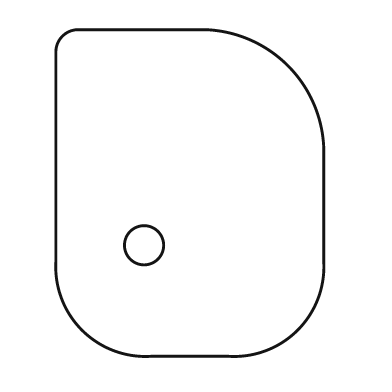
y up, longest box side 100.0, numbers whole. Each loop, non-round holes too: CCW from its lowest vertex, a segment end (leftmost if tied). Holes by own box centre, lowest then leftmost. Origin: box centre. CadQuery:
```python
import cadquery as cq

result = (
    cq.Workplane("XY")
    .moveTo(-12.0, -50.0)
    .lineTo(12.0, -50.0)
    .threePointArc((33.0, -42.0), (41.0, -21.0))
    .lineTo(41.0, 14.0)
    .threePointArc((30.0, 39.0), (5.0, 50.0))
    .lineTo(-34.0, 50.0)
    .threePointArc((-39.0, 48.0), (-41.0, 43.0))
    .lineTo(-41.0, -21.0)
    .threePointArc((-33.0, -42.0), (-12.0, -50.0))
    .close()
    .moveTo(-14.0, -16.0)
    .circle(6.0)
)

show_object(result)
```